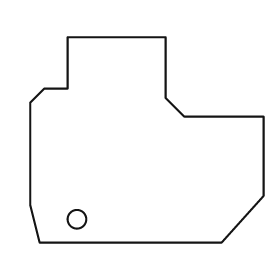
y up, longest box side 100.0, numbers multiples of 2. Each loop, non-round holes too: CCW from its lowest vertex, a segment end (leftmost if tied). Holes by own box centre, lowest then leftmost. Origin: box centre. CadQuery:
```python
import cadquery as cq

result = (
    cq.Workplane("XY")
    .moveTo(-46.0, -44.0)
    .lineTo(32.0, -44.0)
    .lineTo(50.0, -24.0)
    .lineTo(50.0, 10.0)
    .lineTo(16.0, 10.0)
    .lineTo(8.0, 18.0)
    .lineTo(8.0, 44.0)
    .lineTo(-34.0, 44.0)
    .lineTo(-34.0, 22.0)
    .lineTo(-44.0, 22.0)
    .lineTo(-50.0, 16.0)
    .lineTo(-50.0, -28.0)
    .close()
    .moveTo(-30.0, -34.0)
    .circle(4.0)
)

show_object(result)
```